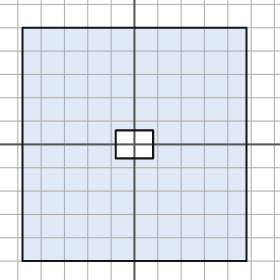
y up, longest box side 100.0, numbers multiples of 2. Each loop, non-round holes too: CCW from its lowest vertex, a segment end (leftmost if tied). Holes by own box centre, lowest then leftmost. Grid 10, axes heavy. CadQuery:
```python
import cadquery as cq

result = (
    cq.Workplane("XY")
    .moveTo(-48.0, -50.0)
    .lineTo(48.0, -50.0)
    .lineTo(48.0, 50.0)
    .lineTo(-48.0, 50.0)
    .close()
    .moveTo(-8.0, -6.0)
    .lineTo(8.0, -6.0)
    .lineTo(8.0, 6.0)
    .lineTo(-8.0, 6.0)
    .close()
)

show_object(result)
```